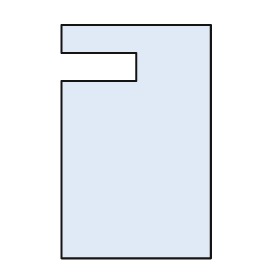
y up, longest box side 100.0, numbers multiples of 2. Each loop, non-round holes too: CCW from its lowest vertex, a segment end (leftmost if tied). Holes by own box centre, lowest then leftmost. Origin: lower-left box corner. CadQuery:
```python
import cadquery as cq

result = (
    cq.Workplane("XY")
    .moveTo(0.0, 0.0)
    .lineTo(64.0, 0.0)
    .lineTo(64.0, 100.0)
    .lineTo(0.0, 100.0)
    .lineTo(0.0, 88.0)
    .lineTo(32.0, 88.0)
    .lineTo(32.0, 76.0)
    .lineTo(0.0, 76.0)
    .close()
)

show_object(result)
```